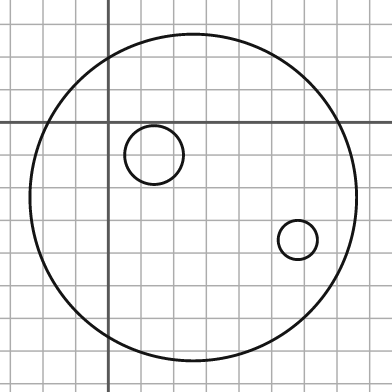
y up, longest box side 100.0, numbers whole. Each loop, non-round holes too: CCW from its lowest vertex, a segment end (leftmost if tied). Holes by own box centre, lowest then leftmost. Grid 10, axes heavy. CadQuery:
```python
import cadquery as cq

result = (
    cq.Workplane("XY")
    .moveTo(26.0, -23.0)
    .circle(50.0)
    .moveTo(58.0, -36.0)
    .circle(6.0)
    .moveTo(14.0, -10.0)
    .circle(9.0)
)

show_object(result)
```